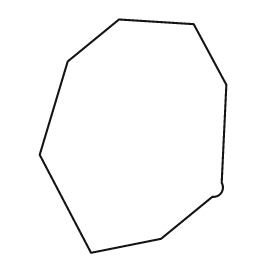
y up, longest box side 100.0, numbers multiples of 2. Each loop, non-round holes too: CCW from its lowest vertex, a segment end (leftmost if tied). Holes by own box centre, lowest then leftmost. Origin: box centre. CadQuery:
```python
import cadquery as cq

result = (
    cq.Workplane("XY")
    .moveTo(-18.0, -50.0)
    .lineTo(12.0, -44.0)
    .lineTo(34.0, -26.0)
    .threePointArc((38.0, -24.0), (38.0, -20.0))
    .lineTo(40.0, 22.0)
    .lineTo(26.0, 48.0)
    .lineTo(-6.0, 50.0)
    .lineTo(-28.0, 32.0)
    .lineTo(-40.0, -8.0)
    .close()
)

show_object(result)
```